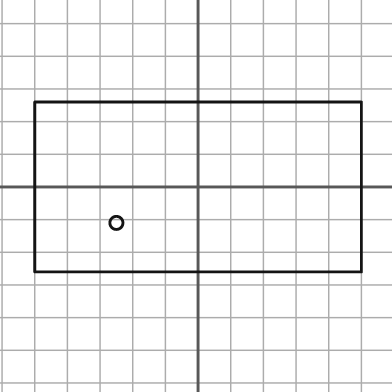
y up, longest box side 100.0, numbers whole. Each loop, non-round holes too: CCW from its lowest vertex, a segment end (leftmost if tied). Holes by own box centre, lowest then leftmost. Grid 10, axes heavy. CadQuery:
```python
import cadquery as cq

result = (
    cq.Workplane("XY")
    .moveTo(-50.0, -26.0)
    .lineTo(50.0, -26.0)
    .lineTo(50.0, 26.0)
    .lineTo(-50.0, 26.0)
    .close()
    .moveTo(-25.0, -11.0)
    .circle(2.0)
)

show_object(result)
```